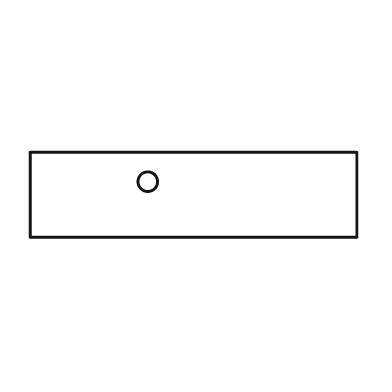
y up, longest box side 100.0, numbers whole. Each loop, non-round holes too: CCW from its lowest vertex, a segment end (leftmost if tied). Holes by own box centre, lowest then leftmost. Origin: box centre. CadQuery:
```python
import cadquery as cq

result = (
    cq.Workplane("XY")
    .moveTo(-50.0, -13.0)
    .lineTo(50.0, -13.0)
    .lineTo(50.0, 13.0)
    .lineTo(-50.0, 13.0)
    .close()
    .moveTo(-14.0, 4.0)
    .circle(3.0)
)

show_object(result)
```